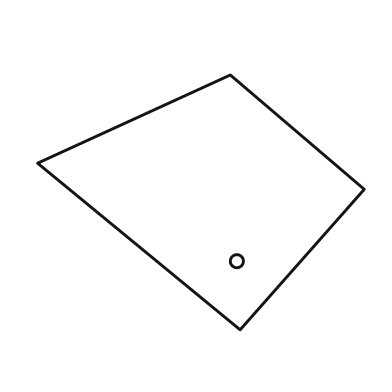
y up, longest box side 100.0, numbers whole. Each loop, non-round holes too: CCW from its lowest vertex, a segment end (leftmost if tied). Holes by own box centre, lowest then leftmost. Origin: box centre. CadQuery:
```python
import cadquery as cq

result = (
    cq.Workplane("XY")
    .moveTo(12.0, -39.0)
    .lineTo(50.0, 4.0)
    .lineTo(9.0, 39.0)
    .lineTo(-50.0, 12.0)
    .close()
    .moveTo(11.0, -18.0)
    .circle(2.0)
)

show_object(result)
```